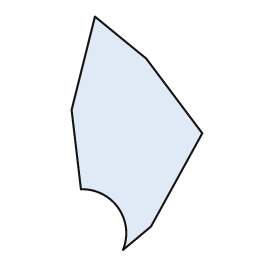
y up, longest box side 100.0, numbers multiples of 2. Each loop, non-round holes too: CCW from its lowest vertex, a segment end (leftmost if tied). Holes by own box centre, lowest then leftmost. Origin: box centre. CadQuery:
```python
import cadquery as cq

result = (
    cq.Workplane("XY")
    .moveTo(-6.0, -50.0)
    .lineTo(6.0, -40.0)
    .lineTo(28.0, 0.0)
    .lineTo(4.0, 32.0)
    .lineTo(-18.0, 50.0)
    .lineTo(-28.0, 10.0)
    .lineTo(-24.0, -24.0)
    .threePointArc((-8.0, -32.0), (-6.0, -50.0))
    .close()
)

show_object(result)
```